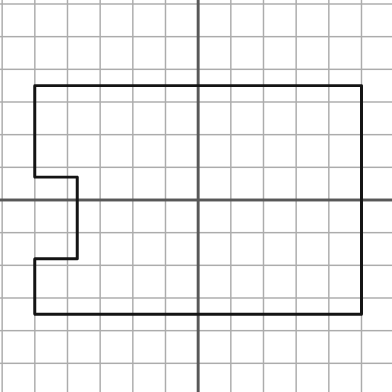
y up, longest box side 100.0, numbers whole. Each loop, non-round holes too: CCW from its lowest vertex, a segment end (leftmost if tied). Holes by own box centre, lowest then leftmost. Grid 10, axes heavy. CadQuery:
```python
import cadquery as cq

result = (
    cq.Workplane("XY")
    .moveTo(-50.0, -35.0)
    .lineTo(50.0, -35.0)
    .lineTo(50.0, 35.0)
    .lineTo(-50.0, 35.0)
    .lineTo(-50.0, 7.0)
    .lineTo(-37.0, 7.0)
    .lineTo(-37.0, -18.0)
    .lineTo(-50.0, -18.0)
    .close()
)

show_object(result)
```